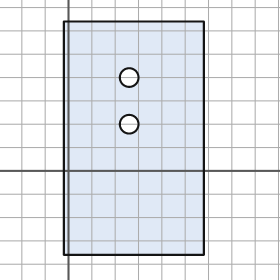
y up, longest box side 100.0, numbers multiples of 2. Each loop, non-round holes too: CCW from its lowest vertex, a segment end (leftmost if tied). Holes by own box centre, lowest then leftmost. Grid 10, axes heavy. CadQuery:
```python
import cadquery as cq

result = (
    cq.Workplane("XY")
    .moveTo(-2.0, -36.0)
    .lineTo(58.0, -36.0)
    .lineTo(58.0, 64.0)
    .lineTo(-2.0, 64.0)
    .close()
    .moveTo(26.0, 20.0)
    .circle(4.0)
    .moveTo(26.0, 40.0)
    .circle(4.0)
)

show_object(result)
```